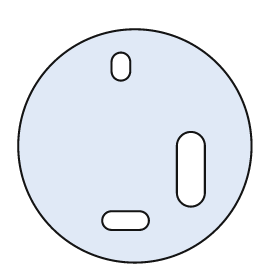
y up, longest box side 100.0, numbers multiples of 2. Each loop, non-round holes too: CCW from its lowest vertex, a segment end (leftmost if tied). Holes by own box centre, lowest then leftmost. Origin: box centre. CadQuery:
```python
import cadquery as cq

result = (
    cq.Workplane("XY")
    .moveTo(0.0, 0.0)
    .circle(50.0)
    .moveTo(-10.0, -36.0)
    .lineTo(2.0, -36.0)
    .threePointArc((6.0, -32.0), (2.0, -28.0))
    .lineTo(-10.0, -28.0)
    .threePointArc((-14.0, -32.0), (-10.0, -36.0))
    .close()
    .moveTo(18.0, -20.0)
    .threePointArc((24.0, -26.0), (30.0, -20.0))
    .lineTo(30.0, 0.0)
    .threePointArc((24.0, 6.0), (18.0, 0.0))
    .close()
    .moveTo(-10.0, 32.0)
    .threePointArc((-6.0, 28.0), (-2.0, 32.0))
    .lineTo(-2.0, 36.0)
    .threePointArc((-6.0, 40.0), (-10.0, 36.0))
    .close()
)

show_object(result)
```